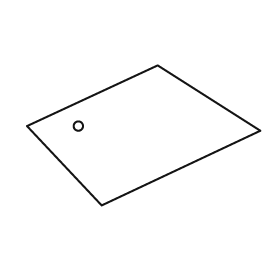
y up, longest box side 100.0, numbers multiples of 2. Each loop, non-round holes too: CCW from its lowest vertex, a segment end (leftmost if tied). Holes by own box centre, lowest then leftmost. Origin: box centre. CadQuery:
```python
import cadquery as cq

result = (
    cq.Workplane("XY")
    .moveTo(-18.0, -30.0)
    .lineTo(50.0, 2.0)
    .lineTo(6.0, 30.0)
    .lineTo(-50.0, 4.0)
    .close()
    .moveTo(-28.0, 4.0)
    .circle(2.0)
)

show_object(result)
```